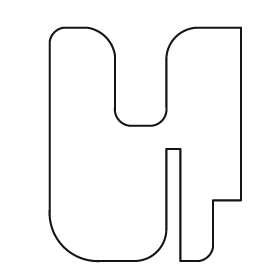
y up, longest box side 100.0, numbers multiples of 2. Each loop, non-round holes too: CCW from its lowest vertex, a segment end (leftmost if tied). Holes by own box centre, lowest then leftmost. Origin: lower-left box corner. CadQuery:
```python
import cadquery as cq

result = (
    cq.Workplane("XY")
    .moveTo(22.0, 0.0)
    .lineTo(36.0, 0.0)
    .threePointArc((46.0, 4.0), (50.0, 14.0))
    .lineTo(50.0, 48.0)
    .lineTo(56.0, 48.0)
    .lineTo(56.0, 0.0)
    .lineTo(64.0, 0.0)
    .threePointArc((68.0, 2.0), (70.0, 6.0))
    .lineTo(70.0, 26.0)
    .lineTo(82.0, 26.0)
    .lineTo(82.0, 100.0)
    .lineTo(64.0, 100.0)
    .threePointArc((54.0, 96.0), (50.0, 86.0))
    .lineTo(50.0, 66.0)
    .threePointArc((48.0, 60.0), (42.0, 58.0))
    .lineTo(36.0, 58.0)
    .threePointArc((30.0, 60.0), (28.0, 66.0))
    .lineTo(28.0, 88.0)
    .threePointArc((24.0, 96.0), (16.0, 100.0))
    .lineTo(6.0, 100.0)
    .threePointArc((2.0, 98.0), (0.0, 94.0))
    .lineTo(0.0, 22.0)
    .threePointArc((6.0, 6.0), (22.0, 0.0))
    .close()
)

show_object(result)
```